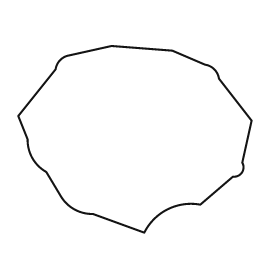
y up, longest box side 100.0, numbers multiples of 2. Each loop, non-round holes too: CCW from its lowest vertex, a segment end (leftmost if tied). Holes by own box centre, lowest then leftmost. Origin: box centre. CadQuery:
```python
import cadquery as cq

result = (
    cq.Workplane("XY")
    .moveTo(4.0, -40.0)
    .threePointArc((14.0, -30.0), (28.0, -28.0))
    .lineTo(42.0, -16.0)
    .threePointArc((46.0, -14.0), (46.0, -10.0))
    .lineTo(50.0, 8.0)
    .lineTo(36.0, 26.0)
    .threePointArc((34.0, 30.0), (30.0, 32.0))
    .lineTo(16.0, 38.0)
    .lineTo(-10.0, 40.0)
    .lineTo(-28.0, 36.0)
    .threePointArc((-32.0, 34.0), (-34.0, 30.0))
    .lineTo(-50.0, 10.0)
    .lineTo(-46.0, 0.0)
    .threePointArc((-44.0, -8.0), (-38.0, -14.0))
    .lineTo(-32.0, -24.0)
    .threePointArc((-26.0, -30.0), (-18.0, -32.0))
    .close()
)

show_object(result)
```